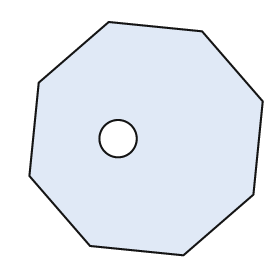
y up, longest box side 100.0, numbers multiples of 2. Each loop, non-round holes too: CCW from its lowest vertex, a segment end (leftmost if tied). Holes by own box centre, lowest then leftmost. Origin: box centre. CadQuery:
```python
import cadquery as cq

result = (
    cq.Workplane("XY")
    .moveTo(16.0, -50.0)
    .lineTo(46.0, -24.0)
    .lineTo(50.0, 16.0)
    .lineTo(24.0, 46.0)
    .lineTo(-16.0, 50.0)
    .lineTo(-46.0, 24.0)
    .lineTo(-50.0, -16.0)
    .lineTo(-24.0, -46.0)
    .close()
    .moveTo(-12.0, 0.0)
    .circle(8.0)
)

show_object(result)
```